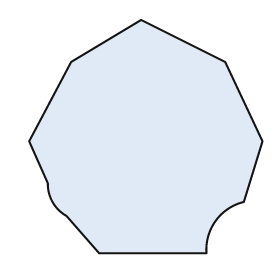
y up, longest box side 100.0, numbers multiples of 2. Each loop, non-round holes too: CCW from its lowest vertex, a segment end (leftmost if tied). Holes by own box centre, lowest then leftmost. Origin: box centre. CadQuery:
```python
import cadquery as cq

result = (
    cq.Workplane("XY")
    .moveTo(-20.0, -50.0)
    .lineTo(26.0, -50.0)
    .threePointArc((30.0, -36.0), (42.0, -28.0))
    .lineTo(50.0, -2.0)
    .lineTo(34.0, 32.0)
    .lineTo(-2.0, 50.0)
    .lineTo(-32.0, 32.0)
    .lineTo(-50.0, -2.0)
    .lineTo(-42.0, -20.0)
    .threePointArc((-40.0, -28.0), (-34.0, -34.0))
    .close()
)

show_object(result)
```